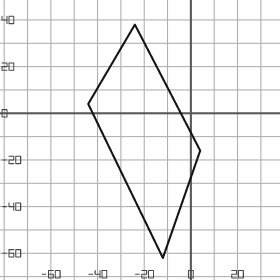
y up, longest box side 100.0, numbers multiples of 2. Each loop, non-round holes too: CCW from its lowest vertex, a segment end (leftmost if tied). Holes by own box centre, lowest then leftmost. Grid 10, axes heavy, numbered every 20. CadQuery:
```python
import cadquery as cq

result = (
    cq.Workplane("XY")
    .moveTo(-12.0, -62.0)
    .lineTo(4.0, -16.0)
    .lineTo(-24.0, 38.0)
    .lineTo(-44.0, 4.0)
    .close()
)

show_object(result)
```